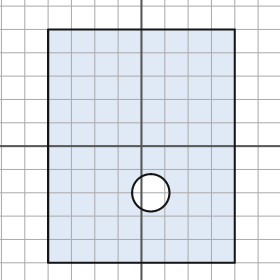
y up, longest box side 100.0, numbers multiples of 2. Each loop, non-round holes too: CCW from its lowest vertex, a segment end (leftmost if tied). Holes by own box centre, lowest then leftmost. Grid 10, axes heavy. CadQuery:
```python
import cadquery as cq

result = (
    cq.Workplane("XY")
    .moveTo(-40.0, -50.0)
    .lineTo(40.0, -50.0)
    .lineTo(40.0, 50.0)
    .lineTo(-40.0, 50.0)
    .close()
    .moveTo(4.0, -20.0)
    .circle(8.0)
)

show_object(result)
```